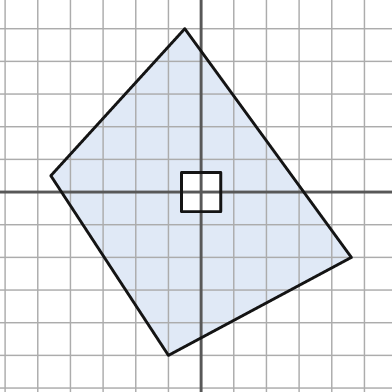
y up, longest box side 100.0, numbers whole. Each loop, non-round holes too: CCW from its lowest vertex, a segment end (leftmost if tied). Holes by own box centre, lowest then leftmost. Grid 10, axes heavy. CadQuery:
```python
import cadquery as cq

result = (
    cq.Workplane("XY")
    .moveTo(-10.0, -50.0)
    .lineTo(46.0, -20.0)
    .lineTo(-5.0, 50.0)
    .lineTo(-46.0, 5.0)
    .close()
    .moveTo(-6.0, -6.0)
    .lineTo(6.0, -6.0)
    .lineTo(6.0, 6.0)
    .lineTo(-6.0, 6.0)
    .close()
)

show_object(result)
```